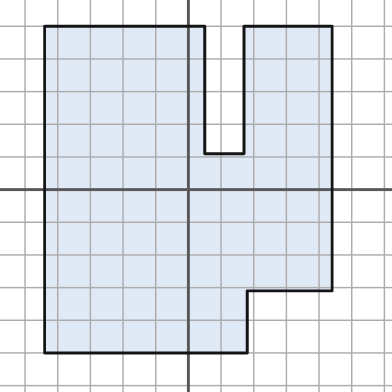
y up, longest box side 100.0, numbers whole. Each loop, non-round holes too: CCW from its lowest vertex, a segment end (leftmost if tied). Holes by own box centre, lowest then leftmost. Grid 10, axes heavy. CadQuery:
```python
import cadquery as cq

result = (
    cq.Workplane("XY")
    .moveTo(-44.0, -50.0)
    .lineTo(18.0, -50.0)
    .lineTo(18.0, -31.0)
    .lineTo(44.0, -31.0)
    .lineTo(44.0, 50.0)
    .lineTo(17.0, 50.0)
    .lineTo(17.0, 11.0)
    .lineTo(5.0, 11.0)
    .lineTo(5.0, 50.0)
    .lineTo(-44.0, 50.0)
    .close()
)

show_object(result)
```